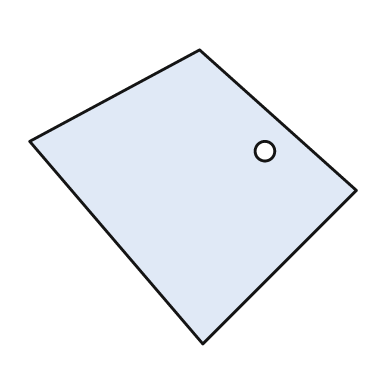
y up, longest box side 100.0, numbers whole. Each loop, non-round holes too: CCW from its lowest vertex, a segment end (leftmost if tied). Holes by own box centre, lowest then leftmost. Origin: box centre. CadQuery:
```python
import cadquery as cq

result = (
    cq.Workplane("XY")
    .moveTo(3.0, -45.0)
    .lineTo(50.0, 2.0)
    .lineTo(2.0, 45.0)
    .lineTo(-50.0, 17.0)
    .close()
    .moveTo(22.0, 14.0)
    .circle(3.0)
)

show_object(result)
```